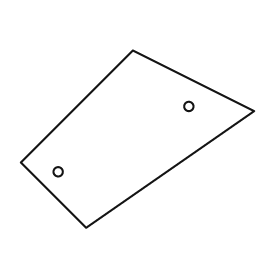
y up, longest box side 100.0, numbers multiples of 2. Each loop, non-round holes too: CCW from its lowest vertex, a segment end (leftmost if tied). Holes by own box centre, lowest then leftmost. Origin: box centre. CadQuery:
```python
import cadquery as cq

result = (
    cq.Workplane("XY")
    .moveTo(-22.0, -38.0)
    .lineTo(50.0, 12.0)
    .lineTo(-2.0, 38.0)
    .lineTo(-50.0, -10.0)
    .close()
    .moveTo(-34.0, -14.0)
    .circle(2.0)
    .moveTo(22.0, 14.0)
    .circle(2.0)
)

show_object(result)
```